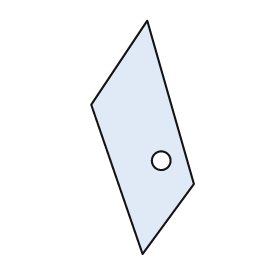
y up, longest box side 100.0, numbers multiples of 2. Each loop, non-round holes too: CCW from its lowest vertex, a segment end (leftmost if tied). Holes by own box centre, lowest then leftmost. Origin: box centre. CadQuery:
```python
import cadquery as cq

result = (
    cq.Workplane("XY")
    .moveTo(0.0, -50.0)
    .lineTo(22.0, -20.0)
    .lineTo(2.0, 50.0)
    .lineTo(-22.0, 14.0)
    .close()
    .moveTo(8.0, -10.0)
    .circle(4.0)
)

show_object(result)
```